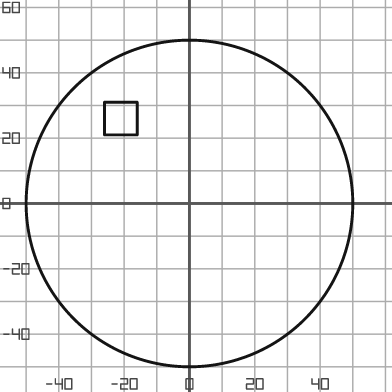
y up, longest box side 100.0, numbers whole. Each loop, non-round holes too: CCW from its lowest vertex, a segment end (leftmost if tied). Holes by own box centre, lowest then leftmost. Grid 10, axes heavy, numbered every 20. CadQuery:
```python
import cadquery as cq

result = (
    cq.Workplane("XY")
    .moveTo(0.0, 0.0)
    .circle(50.0)
    .moveTo(-26.0, 21.0)
    .lineTo(-16.0, 21.0)
    .lineTo(-16.0, 31.0)
    .lineTo(-26.0, 31.0)
    .close()
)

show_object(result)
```